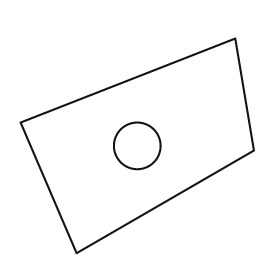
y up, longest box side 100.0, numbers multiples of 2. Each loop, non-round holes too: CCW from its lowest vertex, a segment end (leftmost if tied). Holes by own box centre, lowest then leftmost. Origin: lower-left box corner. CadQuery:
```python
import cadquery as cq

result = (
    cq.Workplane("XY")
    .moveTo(24.0, 0.0)
    .lineTo(100.0, 44.0)
    .lineTo(92.0, 92.0)
    .lineTo(0.0, 56.0)
    .close()
    .moveTo(50.0, 46.0)
    .circle(10.0)
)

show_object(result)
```